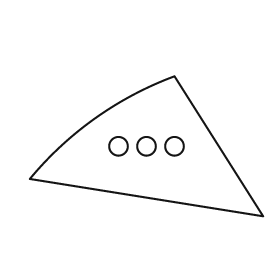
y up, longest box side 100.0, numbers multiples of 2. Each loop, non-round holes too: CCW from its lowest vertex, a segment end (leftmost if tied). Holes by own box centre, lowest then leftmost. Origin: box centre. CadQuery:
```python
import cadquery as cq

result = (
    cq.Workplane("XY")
    .moveTo(50.0, -30.0)
    .lineTo(12.0, 30.0)
    .threePointArc((-22.0, 12.0), (-50.0, -14.0))
    .close()
    .moveTo(-12.0, 0.0)
    .circle(4.0)
    .moveTo(0.0, 0.0)
    .circle(4.0)
    .moveTo(12.0, 0.0)
    .circle(4.0)
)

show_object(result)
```